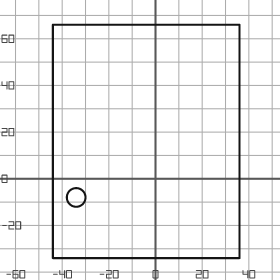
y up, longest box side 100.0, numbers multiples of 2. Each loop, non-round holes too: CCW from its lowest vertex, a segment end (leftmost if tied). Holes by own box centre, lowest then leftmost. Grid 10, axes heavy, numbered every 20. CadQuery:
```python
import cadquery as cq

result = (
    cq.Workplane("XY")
    .moveTo(-44.0, -34.0)
    .lineTo(36.0, -34.0)
    .lineTo(36.0, 66.0)
    .lineTo(-44.0, 66.0)
    .close()
    .moveTo(-34.0, -8.0)
    .circle(4.0)
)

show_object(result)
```